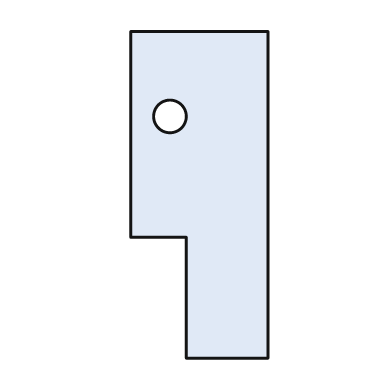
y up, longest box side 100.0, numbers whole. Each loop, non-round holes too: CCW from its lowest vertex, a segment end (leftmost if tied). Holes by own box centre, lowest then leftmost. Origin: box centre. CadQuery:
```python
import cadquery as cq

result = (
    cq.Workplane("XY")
    .moveTo(-4.0, -50.0)
    .lineTo(21.0, -50.0)
    .lineTo(21.0, 50.0)
    .lineTo(-21.0, 50.0)
    .lineTo(-21.0, -13.0)
    .lineTo(-4.0, -13.0)
    .close()
    .moveTo(-9.0, 24.0)
    .circle(5.0)
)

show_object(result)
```